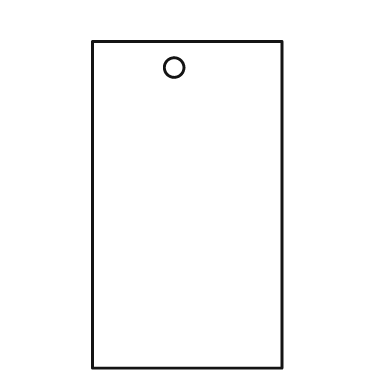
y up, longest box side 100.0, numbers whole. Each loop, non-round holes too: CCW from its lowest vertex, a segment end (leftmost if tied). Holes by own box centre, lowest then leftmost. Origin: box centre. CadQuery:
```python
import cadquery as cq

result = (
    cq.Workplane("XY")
    .moveTo(-29.0, -50.0)
    .lineTo(29.0, -50.0)
    .lineTo(29.0, 50.0)
    .lineTo(-29.0, 50.0)
    .close()
    .moveTo(-4.0, 42.0)
    .circle(3.0)
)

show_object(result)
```